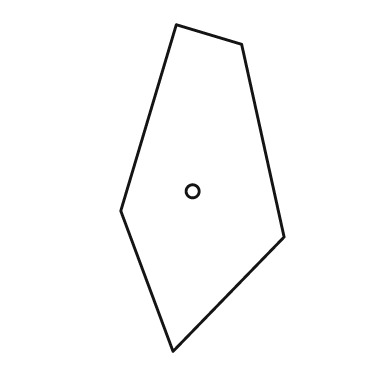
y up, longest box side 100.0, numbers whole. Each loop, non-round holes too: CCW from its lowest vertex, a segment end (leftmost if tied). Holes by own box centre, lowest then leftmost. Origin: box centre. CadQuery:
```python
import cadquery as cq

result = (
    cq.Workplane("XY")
    .moveTo(-9.0, -50.0)
    .lineTo(25.0, -15.0)
    .lineTo(12.0, 44.0)
    .lineTo(-8.0, 50.0)
    .lineTo(-25.0, -7.0)
    .close()
    .moveTo(-3.0, -1.0)
    .circle(2.0)
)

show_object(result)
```